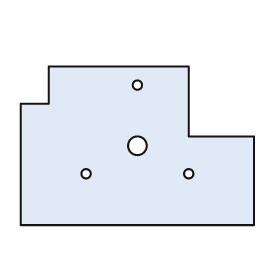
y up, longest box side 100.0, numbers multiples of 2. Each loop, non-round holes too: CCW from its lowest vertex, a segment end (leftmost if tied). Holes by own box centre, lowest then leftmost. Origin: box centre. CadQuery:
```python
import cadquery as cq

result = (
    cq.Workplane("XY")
    .moveTo(-50.0, -34.0)
    .lineTo(50.0, -34.0)
    .lineTo(50.0, 4.0)
    .lineTo(22.0, 4.0)
    .lineTo(22.0, 34.0)
    .lineTo(-38.0, 34.0)
    .lineTo(-38.0, 18.0)
    .lineTo(-50.0, 18.0)
    .close()
    .moveTo(-22.0, -12.0)
    .circle(2.0)
    .moveTo(22.0, -12.0)
    .circle(2.0)
    .moveTo(0.0, 0.0)
    .circle(4.0)
    .moveTo(0.0, 26.0)
    .circle(2.0)
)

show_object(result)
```